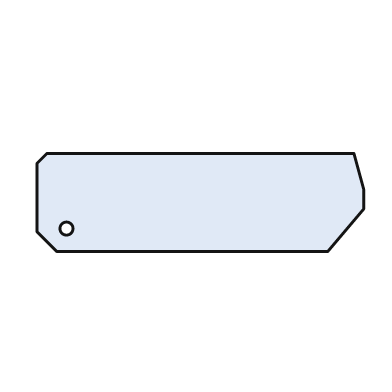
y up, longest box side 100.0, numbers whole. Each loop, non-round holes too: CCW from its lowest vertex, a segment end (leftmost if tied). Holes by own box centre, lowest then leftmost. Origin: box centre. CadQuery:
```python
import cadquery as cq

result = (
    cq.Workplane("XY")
    .moveTo(-44.0, -15.0)
    .lineTo(39.0, -15.0)
    .lineTo(50.0, -2.0)
    .lineTo(50.0, 4.0)
    .lineTo(47.0, 15.0)
    .lineTo(-47.0, 15.0)
    .lineTo(-50.0, 12.0)
    .lineTo(-50.0, -9.0)
    .close()
    .moveTo(-41.0, -8.0)
    .circle(2.0)
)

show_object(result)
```